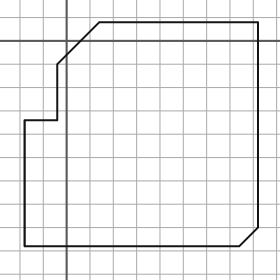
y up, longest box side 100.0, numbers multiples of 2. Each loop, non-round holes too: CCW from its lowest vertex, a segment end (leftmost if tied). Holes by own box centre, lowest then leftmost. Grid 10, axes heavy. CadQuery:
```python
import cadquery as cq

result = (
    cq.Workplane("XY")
    .moveTo(-18.0, -88.0)
    .lineTo(74.0, -88.0)
    .lineTo(82.0, -80.0)
    .lineTo(82.0, 8.0)
    .lineTo(14.0, 8.0)
    .lineTo(-4.0, -10.0)
    .lineTo(-4.0, -34.0)
    .lineTo(-18.0, -34.0)
    .close()
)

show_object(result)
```